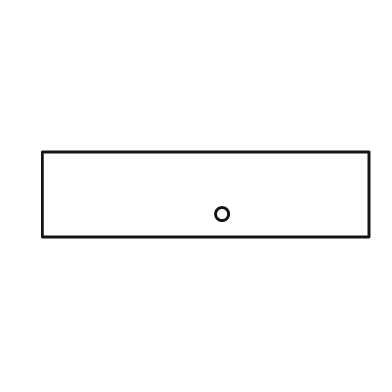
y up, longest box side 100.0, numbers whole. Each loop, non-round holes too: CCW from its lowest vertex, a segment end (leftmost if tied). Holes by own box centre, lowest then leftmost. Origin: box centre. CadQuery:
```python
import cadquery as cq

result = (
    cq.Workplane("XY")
    .moveTo(-50.0, -13.0)
    .lineTo(50.0, -13.0)
    .lineTo(50.0, 13.0)
    .lineTo(-50.0, 13.0)
    .close()
    .moveTo(5.0, -6.0)
    .circle(2.0)
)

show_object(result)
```